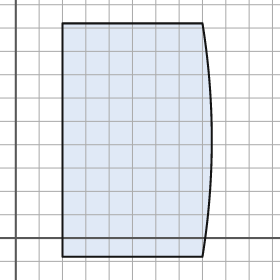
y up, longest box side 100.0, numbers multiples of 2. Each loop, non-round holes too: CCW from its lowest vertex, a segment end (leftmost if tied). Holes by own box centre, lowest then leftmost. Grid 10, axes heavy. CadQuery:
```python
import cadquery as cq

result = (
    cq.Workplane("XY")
    .moveTo(20.0, -8.0)
    .lineTo(80.0, -8.0)
    .threePointArc((84.0, 42.0), (80.0, 92.0))
    .lineTo(20.0, 92.0)
    .close()
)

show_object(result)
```